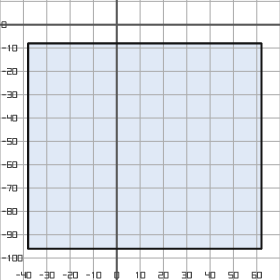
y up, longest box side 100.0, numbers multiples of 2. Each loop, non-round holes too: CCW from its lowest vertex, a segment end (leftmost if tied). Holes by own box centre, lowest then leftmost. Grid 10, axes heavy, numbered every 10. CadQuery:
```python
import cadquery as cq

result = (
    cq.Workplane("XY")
    .moveTo(-38.0, -96.0)
    .lineTo(62.0, -96.0)
    .lineTo(62.0, -8.0)
    .lineTo(-38.0, -8.0)
    .close()
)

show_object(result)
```